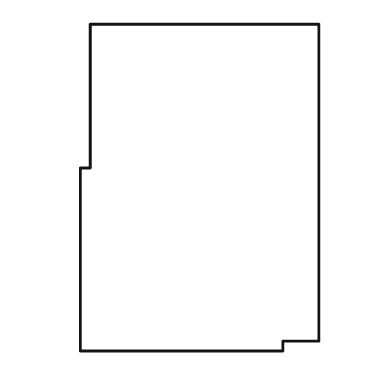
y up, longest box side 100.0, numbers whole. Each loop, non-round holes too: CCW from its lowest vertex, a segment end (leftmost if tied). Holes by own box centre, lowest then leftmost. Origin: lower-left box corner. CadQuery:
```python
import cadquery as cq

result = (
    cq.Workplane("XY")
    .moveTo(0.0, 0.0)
    .lineTo(62.0, 0.0)
    .lineTo(62.0, 3.0)
    .lineTo(73.0, 3.0)
    .lineTo(73.0, 100.0)
    .lineTo(3.0, 100.0)
    .lineTo(3.0, 56.0)
    .lineTo(0.0, 56.0)
    .close()
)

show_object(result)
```